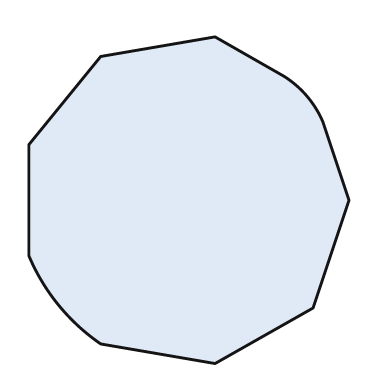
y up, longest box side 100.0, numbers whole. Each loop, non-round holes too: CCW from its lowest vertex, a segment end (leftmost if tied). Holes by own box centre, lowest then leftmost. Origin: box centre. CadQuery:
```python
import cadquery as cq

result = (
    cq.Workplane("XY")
    .moveTo(8.0, -50.0)
    .lineTo(38.0, -33.0)
    .lineTo(49.0, 0.0)
    .lineTo(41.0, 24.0)
    .threePointArc((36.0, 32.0), (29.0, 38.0))
    .lineTo(8.0, 50.0)
    .lineTo(-27.0, 44.0)
    .lineTo(-49.0, 17.0)
    .lineTo(-49.0, -17.0)
    .threePointArc((-40.0, -32.0), (-27.0, -44.0))
    .close()
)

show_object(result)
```